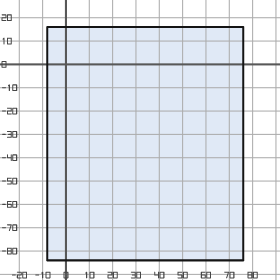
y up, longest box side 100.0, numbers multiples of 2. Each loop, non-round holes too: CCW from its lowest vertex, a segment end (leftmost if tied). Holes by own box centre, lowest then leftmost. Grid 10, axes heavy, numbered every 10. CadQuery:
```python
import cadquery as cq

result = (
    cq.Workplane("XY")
    .moveTo(-8.0, -84.0)
    .lineTo(76.0, -84.0)
    .lineTo(76.0, 16.0)
    .lineTo(-8.0, 16.0)
    .close()
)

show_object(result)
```